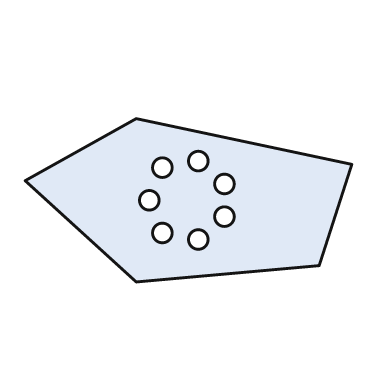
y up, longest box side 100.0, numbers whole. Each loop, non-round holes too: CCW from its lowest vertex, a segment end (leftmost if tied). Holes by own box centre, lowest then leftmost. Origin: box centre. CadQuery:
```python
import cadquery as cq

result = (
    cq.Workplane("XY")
    .moveTo(-16.0, -25.0)
    .lineTo(40.0, -20.0)
    .lineTo(50.0, 11.0)
    .lineTo(-16.0, 25.0)
    .lineTo(-50.0, 6.0)
    .close()
    .moveTo(3.0, -12.0)
    .circle(3.0)
    .moveTo(-8.0, -10.0)
    .circle(3.0)
    .moveTo(11.0, -5.0)
    .circle(3.0)
    .moveTo(-12.0, 0.0)
    .circle(3.0)
    .moveTo(11.0, 5.0)
    .circle(3.0)
    .moveTo(-8.0, 10.0)
    .circle(3.0)
    .moveTo(3.0, 12.0)
    .circle(3.0)
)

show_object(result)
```